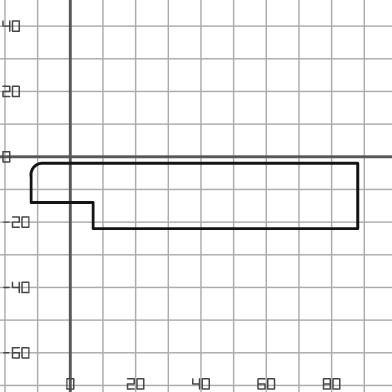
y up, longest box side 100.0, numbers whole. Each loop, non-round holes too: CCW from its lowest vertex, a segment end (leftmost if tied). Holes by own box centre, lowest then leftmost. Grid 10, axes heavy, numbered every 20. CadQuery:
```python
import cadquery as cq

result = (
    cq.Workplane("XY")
    .moveTo(7.0, -22.0)
    .lineTo(88.0, -22.0)
    .lineTo(88.0, -2.0)
    .lineTo(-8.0, -2.0)
    .threePointArc((-11.0, -3.0), (-12.0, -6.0))
    .lineTo(-12.0, -14.0)
    .lineTo(7.0, -14.0)
    .close()
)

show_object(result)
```